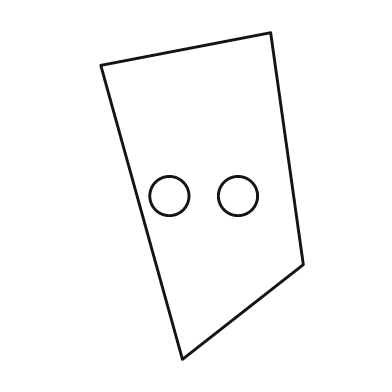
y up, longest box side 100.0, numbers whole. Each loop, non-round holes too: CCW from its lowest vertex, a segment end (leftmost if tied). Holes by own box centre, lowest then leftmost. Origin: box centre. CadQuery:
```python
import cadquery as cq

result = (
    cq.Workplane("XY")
    .moveTo(-6.0, -50.0)
    .lineTo(31.0, -21.0)
    .lineTo(21.0, 50.0)
    .lineTo(-31.0, 40.0)
    .close()
    .moveTo(-10.0, 0.0)
    .circle(6.0)
    .moveTo(11.0, 0.0)
    .circle(6.0)
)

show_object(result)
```